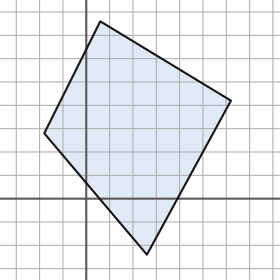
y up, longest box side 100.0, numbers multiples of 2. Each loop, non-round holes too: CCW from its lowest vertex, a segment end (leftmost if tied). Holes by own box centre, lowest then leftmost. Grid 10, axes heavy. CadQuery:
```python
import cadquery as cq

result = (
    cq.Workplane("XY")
    .moveTo(26.0, -24.0)
    .lineTo(62.0, 42.0)
    .lineTo(6.0, 76.0)
    .lineTo(-18.0, 28.0)
    .close()
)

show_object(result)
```